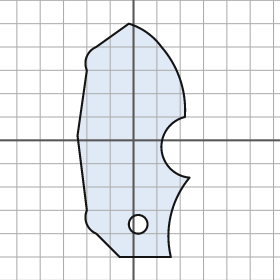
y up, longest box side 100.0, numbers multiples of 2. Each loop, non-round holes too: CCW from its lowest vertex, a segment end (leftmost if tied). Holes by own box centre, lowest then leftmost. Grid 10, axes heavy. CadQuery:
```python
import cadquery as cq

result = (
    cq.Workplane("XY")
    .moveTo(-6.0, -50.0)
    .lineTo(16.0, -50.0)
    .threePointArc((16.0, -32.0), (24.0, -16.0))
    .threePointArc((12.0, -4.0), (22.0, 10.0))
    .threePointArc((20.0, 26.0), (12.0, 40.0))
    .threePointArc((6.0, 46.0), (-2.0, 50.0))
    .lineTo(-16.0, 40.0)
    .threePointArc((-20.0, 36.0), (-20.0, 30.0))
    .lineTo(-24.0, 2.0)
    .lineTo(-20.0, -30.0)
    .threePointArc((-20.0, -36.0), (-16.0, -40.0))
    .close()
    .moveTo(2.0, -36.0)
    .circle(4.0)
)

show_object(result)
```